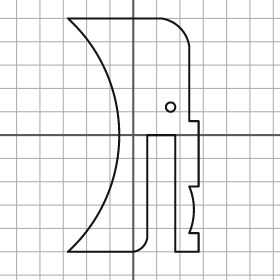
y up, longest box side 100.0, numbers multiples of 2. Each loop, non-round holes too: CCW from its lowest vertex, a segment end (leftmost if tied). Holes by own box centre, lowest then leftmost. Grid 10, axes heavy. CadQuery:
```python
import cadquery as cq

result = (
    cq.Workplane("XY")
    .moveTo(-28.0, -50.0)
    .lineTo(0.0, -50.0)
    .threePointArc((4.0, -48.0), (6.0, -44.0))
    .lineTo(6.0, 0.0)
    .lineTo(18.0, 0.0)
    .lineTo(18.0, -50.0)
    .lineTo(28.0, -50.0)
    .lineTo(28.0, -42.0)
    .lineTo(24.0, -42.0)
    .threePointArc((26.0, -32.0), (24.0, -22.0))
    .lineTo(28.0, -22.0)
    .lineTo(28.0, 6.0)
    .lineTo(24.0, 6.0)
    .lineTo(24.0, 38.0)
    .threePointArc((20.0, 46.0), (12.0, 50.0))
    .lineTo(-28.0, 50.0)
    .threePointArc((-6.0, 0.0), (-28.0, -50.0))
    .close()
    .moveTo(16.0, 12.0)
    .circle(2.0)
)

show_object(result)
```